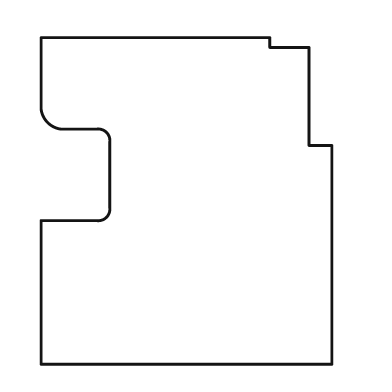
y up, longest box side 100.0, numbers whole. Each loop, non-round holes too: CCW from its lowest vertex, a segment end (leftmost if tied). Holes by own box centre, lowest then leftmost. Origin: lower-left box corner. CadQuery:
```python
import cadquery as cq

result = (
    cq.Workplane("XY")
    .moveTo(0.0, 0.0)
    .lineTo(89.0, 0.0)
    .lineTo(89.0, 67.0)
    .lineTo(82.0, 67.0)
    .lineTo(82.0, 97.0)
    .lineTo(70.0, 97.0)
    .lineTo(70.0, 100.0)
    .lineTo(0.0, 100.0)
    .lineTo(0.0, 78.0)
    .threePointArc((2.0, 74.0), (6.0, 72.0))
    .lineTo(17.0, 72.0)
    .threePointArc((20.0, 71.0), (21.0, 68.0))
    .lineTo(21.0, 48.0)
    .threePointArc((20.0, 45.0), (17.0, 44.0))
    .lineTo(0.0, 44.0)
    .close()
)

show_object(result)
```